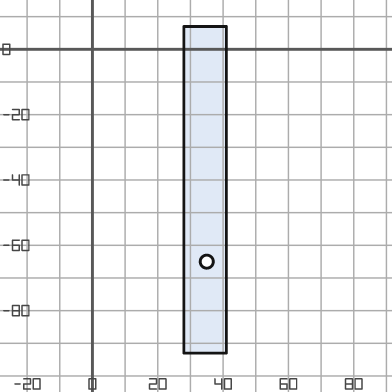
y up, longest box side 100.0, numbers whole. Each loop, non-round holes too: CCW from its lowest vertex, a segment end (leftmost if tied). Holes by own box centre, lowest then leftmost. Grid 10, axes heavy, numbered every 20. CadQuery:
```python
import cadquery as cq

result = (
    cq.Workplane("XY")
    .moveTo(28.0, -93.0)
    .lineTo(41.0, -93.0)
    .lineTo(41.0, 7.0)
    .lineTo(28.0, 7.0)
    .close()
    .moveTo(35.0, -65.0)
    .circle(2.0)
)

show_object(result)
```